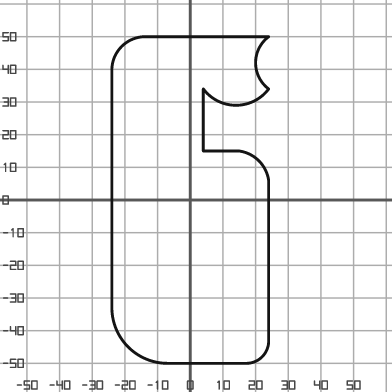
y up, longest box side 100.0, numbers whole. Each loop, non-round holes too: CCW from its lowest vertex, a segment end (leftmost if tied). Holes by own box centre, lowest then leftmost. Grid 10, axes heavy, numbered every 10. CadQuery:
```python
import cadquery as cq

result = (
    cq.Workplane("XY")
    .moveTo(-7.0, -50.0)
    .lineTo(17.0, -50.0)
    .threePointArc((22.0, -48.0), (24.0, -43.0))
    .lineTo(24.0, 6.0)
    .threePointArc((21.0, 12.0), (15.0, 15.0))
    .lineTo(4.0, 15.0)
    .lineTo(4.0, 34.0)
    .threePointArc((14.0, 29.0), (24.0, 34.0))
    .threePointArc((20.0, 42.0), (24.0, 50.0))
    .lineTo(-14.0, 50.0)
    .threePointArc((-21.0, 47.0), (-24.0, 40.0))
    .lineTo(-24.0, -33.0)
    .threePointArc((-19.0, -45.0), (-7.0, -50.0))
    .close()
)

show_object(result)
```